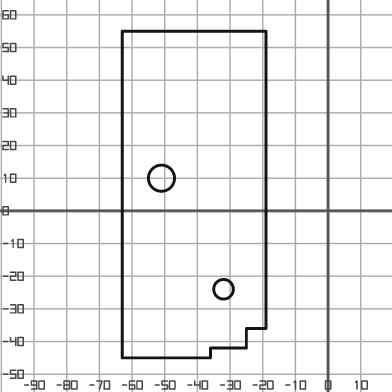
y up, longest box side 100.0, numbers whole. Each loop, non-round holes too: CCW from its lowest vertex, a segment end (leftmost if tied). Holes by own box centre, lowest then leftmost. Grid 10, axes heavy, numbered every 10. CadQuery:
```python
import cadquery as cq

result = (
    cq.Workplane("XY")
    .moveTo(-63.0, -45.0)
    .lineTo(-36.0, -45.0)
    .lineTo(-36.0, -42.0)
    .lineTo(-25.0, -42.0)
    .lineTo(-25.0, -36.0)
    .lineTo(-19.0, -36.0)
    .lineTo(-19.0, 55.0)
    .lineTo(-63.0, 55.0)
    .close()
    .moveTo(-32.0, -24.0)
    .circle(3.0)
    .moveTo(-51.0, 10.0)
    .circle(4.0)
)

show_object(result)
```